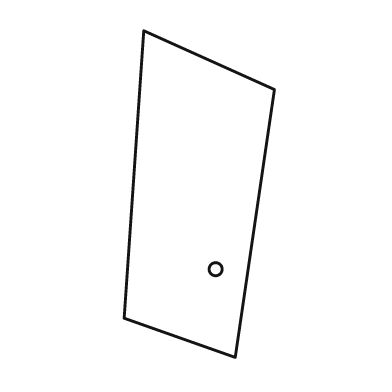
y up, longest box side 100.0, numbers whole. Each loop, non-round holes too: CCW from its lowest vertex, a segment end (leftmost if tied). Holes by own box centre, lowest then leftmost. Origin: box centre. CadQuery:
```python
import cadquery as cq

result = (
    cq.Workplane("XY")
    .moveTo(11.0, -50.0)
    .lineTo(23.0, 32.0)
    .lineTo(-17.0, 50.0)
    .lineTo(-23.0, -38.0)
    .close()
    .moveTo(5.0, -23.0)
    .circle(2.0)
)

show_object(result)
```